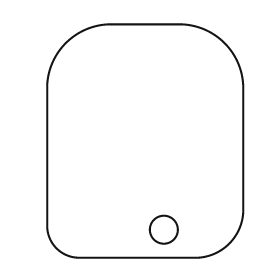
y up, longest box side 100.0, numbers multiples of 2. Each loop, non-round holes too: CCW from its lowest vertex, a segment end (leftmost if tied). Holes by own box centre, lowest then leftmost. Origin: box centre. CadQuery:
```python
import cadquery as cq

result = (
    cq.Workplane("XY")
    .moveTo(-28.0, -50.0)
    .lineTo(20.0, -50.0)
    .threePointArc((36.0, -44.0), (42.0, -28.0))
    .lineTo(42.0, 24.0)
    .threePointArc((34.0, 42.0), (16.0, 50.0))
    .lineTo(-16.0, 50.0)
    .threePointArc((-34.0, 42.0), (-42.0, 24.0))
    .lineTo(-42.0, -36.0)
    .threePointArc((-38.0, -46.0), (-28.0, -50.0))
    .close()
    .moveTo(8.0, -38.0)
    .circle(6.0)
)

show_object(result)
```